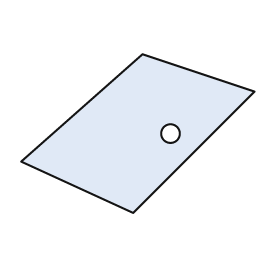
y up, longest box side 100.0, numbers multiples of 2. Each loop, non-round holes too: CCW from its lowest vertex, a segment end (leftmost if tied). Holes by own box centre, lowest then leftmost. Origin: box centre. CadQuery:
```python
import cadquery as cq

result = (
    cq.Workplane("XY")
    .moveTo(-2.0, -34.0)
    .lineTo(50.0, 18.0)
    .lineTo(2.0, 34.0)
    .lineTo(-50.0, -12.0)
    .close()
    .moveTo(14.0, 0.0)
    .circle(4.0)
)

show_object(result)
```